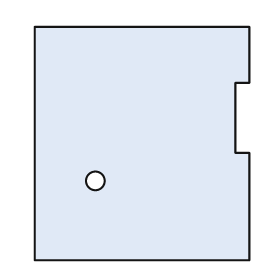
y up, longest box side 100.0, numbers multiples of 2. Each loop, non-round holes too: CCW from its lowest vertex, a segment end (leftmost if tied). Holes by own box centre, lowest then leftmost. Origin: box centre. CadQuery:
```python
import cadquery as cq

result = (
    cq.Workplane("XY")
    .moveTo(-46.0, -50.0)
    .lineTo(46.0, -50.0)
    .lineTo(46.0, -4.0)
    .lineTo(40.0, -4.0)
    .lineTo(40.0, 26.0)
    .lineTo(46.0, 26.0)
    .lineTo(46.0, 50.0)
    .lineTo(-46.0, 50.0)
    .close()
    .moveTo(-20.0, -16.0)
    .circle(4.0)
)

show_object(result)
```